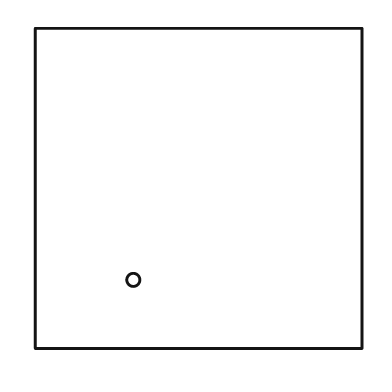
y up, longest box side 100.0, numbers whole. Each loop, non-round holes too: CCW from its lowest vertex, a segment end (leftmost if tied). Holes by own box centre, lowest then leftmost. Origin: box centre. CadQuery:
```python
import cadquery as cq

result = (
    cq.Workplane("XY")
    .moveTo(-50.0, -49.0)
    .lineTo(50.0, -49.0)
    .lineTo(50.0, 49.0)
    .lineTo(-50.0, 49.0)
    .close()
    .moveTo(-20.0, -28.0)
    .circle(2.0)
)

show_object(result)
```